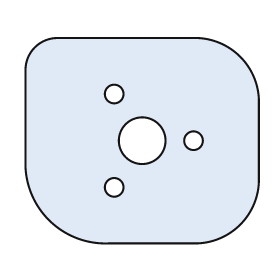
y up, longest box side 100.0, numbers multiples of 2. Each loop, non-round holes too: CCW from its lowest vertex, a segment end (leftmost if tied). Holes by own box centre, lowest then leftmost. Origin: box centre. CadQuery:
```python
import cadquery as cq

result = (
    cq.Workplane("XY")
    .moveTo(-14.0, -44.0)
    .lineTo(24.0, -44.0)
    .threePointArc((42.0, -36.0), (50.0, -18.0))
    .lineTo(50.0, 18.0)
    .threePointArc((42.0, 36.0), (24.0, 44.0))
    .lineTo(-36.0, 44.0)
    .threePointArc((-46.0, 40.0), (-50.0, 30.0))
    .lineTo(-50.0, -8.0)
    .threePointArc((-40.0, -34.0), (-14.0, -44.0))
    .close()
    .moveTo(-12.0, -20.0)
    .circle(4.0)
    .moveTo(0.0, 0.0)
    .circle(10.0)
    .moveTo(22.0, 0.0)
    .circle(4.0)
    .moveTo(-12.0, 20.0)
    .circle(4.0)
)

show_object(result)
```